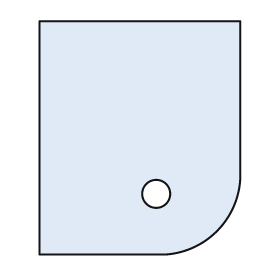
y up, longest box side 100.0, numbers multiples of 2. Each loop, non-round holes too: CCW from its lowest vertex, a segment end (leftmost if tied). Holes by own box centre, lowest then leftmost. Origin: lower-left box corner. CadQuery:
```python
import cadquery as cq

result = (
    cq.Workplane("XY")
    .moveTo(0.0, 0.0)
    .lineTo(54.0, 0.0)
    .threePointArc((76.0, 10.0), (86.0, 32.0))
    .lineTo(86.0, 100.0)
    .lineTo(0.0, 100.0)
    .close()
    .moveTo(50.0, 26.0)
    .circle(6.0)
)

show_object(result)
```